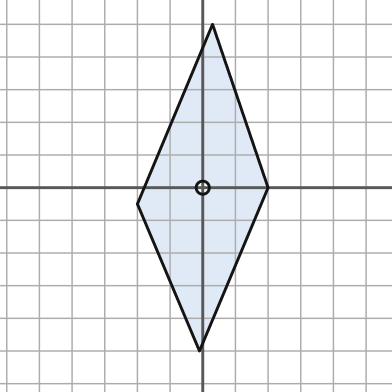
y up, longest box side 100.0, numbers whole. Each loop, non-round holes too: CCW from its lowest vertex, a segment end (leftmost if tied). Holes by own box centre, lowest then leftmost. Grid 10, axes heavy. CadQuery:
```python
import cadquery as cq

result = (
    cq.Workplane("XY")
    .moveTo(-1.0, -50.0)
    .lineTo(20.0, 0.0)
    .lineTo(3.0, 50.0)
    .lineTo(-20.0, -5.0)
    .close()
    .moveTo(0.0, 0.0)
    .circle(2.0)
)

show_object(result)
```